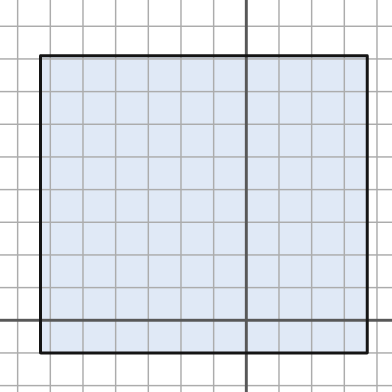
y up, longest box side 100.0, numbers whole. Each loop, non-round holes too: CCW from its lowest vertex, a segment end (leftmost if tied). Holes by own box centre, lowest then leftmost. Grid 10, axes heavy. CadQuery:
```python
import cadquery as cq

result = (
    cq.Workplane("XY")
    .moveTo(-63.0, -10.0)
    .lineTo(37.0, -10.0)
    .lineTo(37.0, 81.0)
    .lineTo(-63.0, 81.0)
    .close()
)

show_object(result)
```